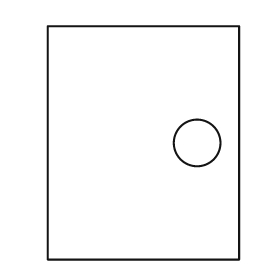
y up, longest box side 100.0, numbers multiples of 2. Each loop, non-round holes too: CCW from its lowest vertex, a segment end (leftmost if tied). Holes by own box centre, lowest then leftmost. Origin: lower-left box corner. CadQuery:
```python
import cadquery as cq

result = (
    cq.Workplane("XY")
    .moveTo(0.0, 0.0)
    .lineTo(82.0, 0.0)
    .lineTo(82.0, 100.0)
    .lineTo(0.0, 100.0)
    .close()
    .moveTo(64.0, 50.0)
    .circle(10.0)
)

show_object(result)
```